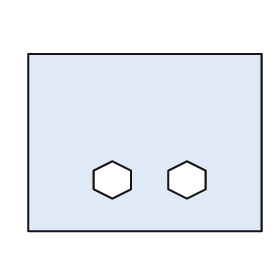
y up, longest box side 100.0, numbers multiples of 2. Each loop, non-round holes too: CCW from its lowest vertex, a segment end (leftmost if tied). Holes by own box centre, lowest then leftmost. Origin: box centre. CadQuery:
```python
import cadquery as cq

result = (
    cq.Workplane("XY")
    .moveTo(-50.0, -38.0)
    .lineTo(50.0, -38.0)
    .lineTo(50.0, 38.0)
    .lineTo(-50.0, 38.0)
    .close()
    .moveTo(-14.0, -24.0)
    .lineTo(-6.0, -20.0)
    .lineTo(-6.0, -12.0)
    .lineTo(-14.0, -8.0)
    .lineTo(-22.0, -12.0)
    .lineTo(-22.0, -20.0)
    .close()
    .moveTo(18.0, -24.0)
    .lineTo(26.0, -20.0)
    .lineTo(26.0, -12.0)
    .lineTo(18.0, -8.0)
    .lineTo(10.0, -12.0)
    .lineTo(10.0, -20.0)
    .close()
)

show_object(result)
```